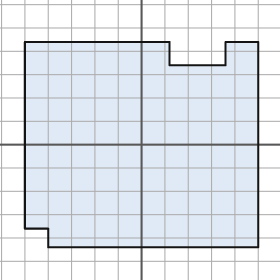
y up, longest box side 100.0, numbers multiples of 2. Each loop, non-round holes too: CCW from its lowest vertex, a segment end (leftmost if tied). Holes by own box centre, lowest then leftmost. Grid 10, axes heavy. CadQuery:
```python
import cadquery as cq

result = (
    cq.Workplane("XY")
    .moveTo(-40.0, -44.0)
    .lineTo(50.0, -44.0)
    .lineTo(50.0, 44.0)
    .lineTo(36.0, 44.0)
    .lineTo(36.0, 34.0)
    .lineTo(12.0, 34.0)
    .lineTo(12.0, 44.0)
    .lineTo(-50.0, 44.0)
    .lineTo(-50.0, -36.0)
    .lineTo(-40.0, -36.0)
    .close()
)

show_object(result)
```